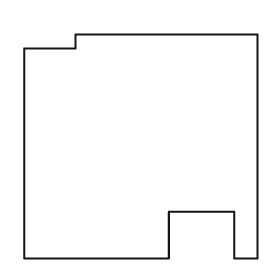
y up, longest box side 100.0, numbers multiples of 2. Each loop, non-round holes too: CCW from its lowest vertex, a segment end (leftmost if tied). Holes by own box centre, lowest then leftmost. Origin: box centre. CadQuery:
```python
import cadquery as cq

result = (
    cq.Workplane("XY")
    .moveTo(-50.0, -48.0)
    .lineTo(12.0, -48.0)
    .lineTo(12.0, -28.0)
    .lineTo(40.0, -28.0)
    .lineTo(40.0, -48.0)
    .lineTo(50.0, -48.0)
    .lineTo(50.0, 48.0)
    .lineTo(-28.0, 48.0)
    .lineTo(-28.0, 42.0)
    .lineTo(-50.0, 42.0)
    .close()
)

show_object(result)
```